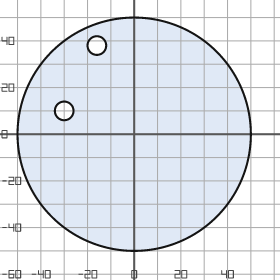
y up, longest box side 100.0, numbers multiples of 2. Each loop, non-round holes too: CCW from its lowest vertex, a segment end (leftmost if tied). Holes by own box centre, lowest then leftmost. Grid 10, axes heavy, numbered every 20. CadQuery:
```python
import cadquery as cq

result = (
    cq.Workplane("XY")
    .moveTo(0.0, 0.0)
    .circle(50.0)
    .moveTo(-30.0, 10.0)
    .circle(4.0)
    .moveTo(-16.0, 38.0)
    .circle(4.0)
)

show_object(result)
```